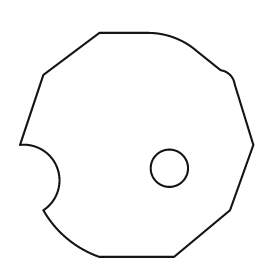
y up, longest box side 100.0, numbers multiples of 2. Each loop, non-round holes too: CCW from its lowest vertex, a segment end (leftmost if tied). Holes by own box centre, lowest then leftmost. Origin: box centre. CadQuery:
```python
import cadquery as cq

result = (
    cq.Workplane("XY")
    .moveTo(-16.0, -48.0)
    .lineTo(16.0, -48.0)
    .lineTo(40.0, -28.0)
    .lineTo(50.0, 0.0)
    .lineTo(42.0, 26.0)
    .threePointArc((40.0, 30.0), (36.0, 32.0))
    .lineTo(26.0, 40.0)
    .threePointArc((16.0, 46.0), (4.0, 48.0))
    .lineTo(-16.0, 48.0)
    .lineTo(-40.0, 30.0)
    .lineTo(-50.0, 0.0)
    .threePointArc((-34.0, -10.0), (-40.0, -28.0))
    .threePointArc((-30.0, -40.0), (-16.0, -48.0))
    .close()
    .moveTo(14.0, -10.0)
    .circle(8.0)
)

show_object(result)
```